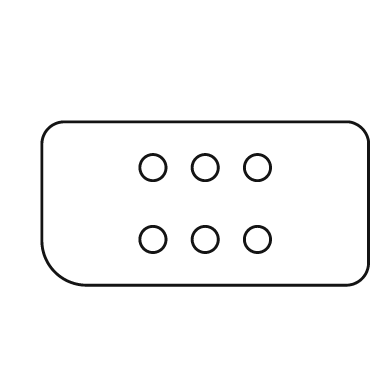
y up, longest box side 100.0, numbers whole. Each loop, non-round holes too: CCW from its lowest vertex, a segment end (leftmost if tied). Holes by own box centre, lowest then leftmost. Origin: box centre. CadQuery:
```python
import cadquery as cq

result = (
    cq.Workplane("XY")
    .moveTo(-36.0, -25.0)
    .lineTo(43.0, -25.0)
    .threePointArc((48.0, -23.0), (50.0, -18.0))
    .lineTo(50.0, 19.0)
    .threePointArc((48.0, 23.0), (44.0, 25.0))
    .lineTo(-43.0, 25.0)
    .threePointArc((-48.0, 23.0), (-50.0, 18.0))
    .lineTo(-50.0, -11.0)
    .threePointArc((-46.0, -21.0), (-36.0, -25.0))
    .close()
    .moveTo(-16.0, -11.0)
    .circle(4.0)
    .moveTo(0.0, -11.0)
    .circle(4.0)
    .moveTo(16.0, -11.0)
    .circle(4.0)
    .moveTo(-16.0, 11.0)
    .circle(4.0)
    .moveTo(0.0, 11.0)
    .circle(4.0)
    .moveTo(16.0, 11.0)
    .circle(4.0)
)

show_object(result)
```